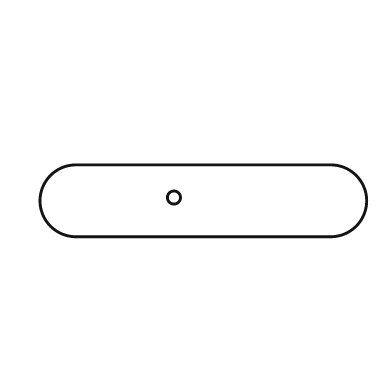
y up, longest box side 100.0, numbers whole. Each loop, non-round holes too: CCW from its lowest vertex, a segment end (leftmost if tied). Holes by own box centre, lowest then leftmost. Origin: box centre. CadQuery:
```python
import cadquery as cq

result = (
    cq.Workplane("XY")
    .moveTo(-39.0, -11.0)
    .lineTo(39.0, -11.0)
    .threePointArc((50.0, 0.0), (39.0, 11.0))
    .lineTo(-39.0, 11.0)
    .threePointArc((-50.0, 0.0), (-39.0, -11.0))
    .close()
    .moveTo(-9.0, 1.0)
    .circle(2.0)
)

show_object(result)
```